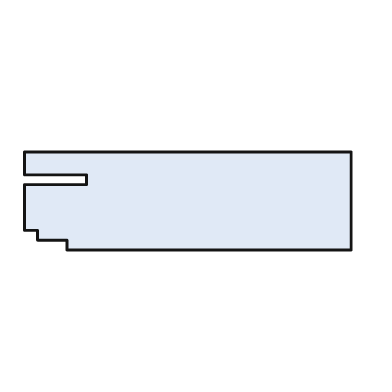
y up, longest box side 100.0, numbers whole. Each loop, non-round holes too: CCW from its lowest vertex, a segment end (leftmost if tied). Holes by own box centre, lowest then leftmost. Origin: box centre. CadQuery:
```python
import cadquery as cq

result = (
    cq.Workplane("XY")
    .moveTo(-37.0, -15.0)
    .lineTo(50.0, -15.0)
    .lineTo(50.0, 15.0)
    .lineTo(-50.0, 15.0)
    .lineTo(-50.0, 8.0)
    .lineTo(-31.0, 8.0)
    .lineTo(-31.0, 5.0)
    .lineTo(-50.0, 5.0)
    .lineTo(-50.0, -9.0)
    .lineTo(-46.0, -9.0)
    .lineTo(-46.0, -12.0)
    .lineTo(-37.0, -12.0)
    .close()
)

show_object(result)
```